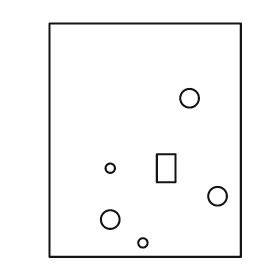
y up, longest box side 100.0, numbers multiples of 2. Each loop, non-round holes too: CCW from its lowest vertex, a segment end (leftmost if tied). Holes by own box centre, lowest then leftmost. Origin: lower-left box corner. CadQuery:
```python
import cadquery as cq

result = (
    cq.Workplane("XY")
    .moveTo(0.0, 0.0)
    .lineTo(82.0, 0.0)
    .lineTo(82.0, 100.0)
    .lineTo(0.0, 100.0)
    .close()
    .moveTo(40.0, 6.0)
    .circle(2.0)
    .moveTo(26.0, 16.0)
    .circle(4.0)
    .moveTo(72.0, 26.0)
    .circle(4.0)
    .moveTo(26.0, 38.0)
    .circle(2.0)
    .moveTo(46.0, 32.0)
    .lineTo(54.0, 32.0)
    .lineTo(54.0, 44.0)
    .lineTo(46.0, 44.0)
    .close()
    .moveTo(60.0, 68.0)
    .circle(4.0)
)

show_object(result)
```